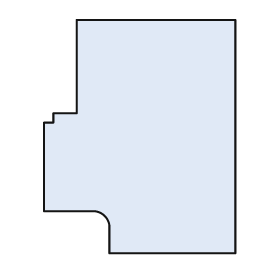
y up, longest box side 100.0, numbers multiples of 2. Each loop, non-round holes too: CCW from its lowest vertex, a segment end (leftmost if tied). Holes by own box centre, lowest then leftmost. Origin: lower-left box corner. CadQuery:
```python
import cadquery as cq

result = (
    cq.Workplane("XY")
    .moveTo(28.0, 0.0)
    .lineTo(82.0, 0.0)
    .lineTo(82.0, 100.0)
    .lineTo(14.0, 100.0)
    .lineTo(14.0, 60.0)
    .lineTo(4.0, 60.0)
    .lineTo(4.0, 56.0)
    .lineTo(0.0, 56.0)
    .lineTo(0.0, 18.0)
    .lineTo(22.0, 18.0)
    .threePointArc((26.0, 16.0), (28.0, 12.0))
    .close()
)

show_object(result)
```